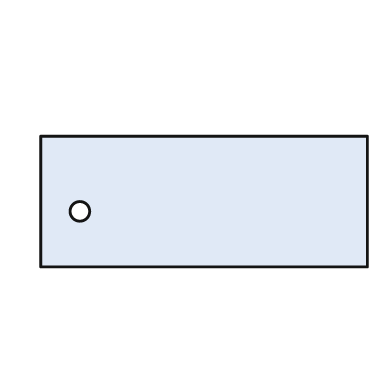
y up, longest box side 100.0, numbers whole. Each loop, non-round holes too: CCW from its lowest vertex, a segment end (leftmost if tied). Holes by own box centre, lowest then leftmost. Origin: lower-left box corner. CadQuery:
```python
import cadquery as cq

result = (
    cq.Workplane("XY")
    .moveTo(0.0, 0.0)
    .lineTo(100.0, 0.0)
    .lineTo(100.0, 40.0)
    .lineTo(0.0, 40.0)
    .close()
    .moveTo(12.0, 17.0)
    .circle(3.0)
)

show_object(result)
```